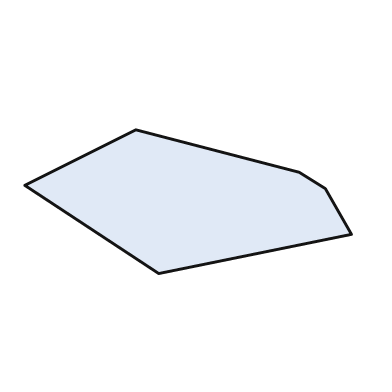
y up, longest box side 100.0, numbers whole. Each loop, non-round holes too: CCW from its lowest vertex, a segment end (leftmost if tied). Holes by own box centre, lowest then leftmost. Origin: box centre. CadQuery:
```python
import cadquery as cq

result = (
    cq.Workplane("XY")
    .moveTo(-9.0, -22.0)
    .lineTo(50.0, -10.0)
    .lineTo(42.0, 4.0)
    .lineTo(34.0, 9.0)
    .lineTo(-16.0, 22.0)
    .lineTo(-50.0, 5.0)
    .close()
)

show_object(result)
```